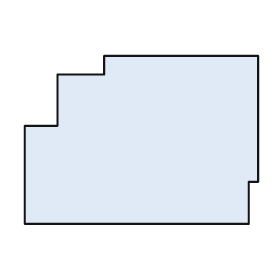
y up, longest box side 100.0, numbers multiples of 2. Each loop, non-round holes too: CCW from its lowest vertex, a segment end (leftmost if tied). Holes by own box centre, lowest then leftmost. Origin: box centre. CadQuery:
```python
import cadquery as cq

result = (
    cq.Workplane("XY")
    .moveTo(-50.0, -36.0)
    .lineTo(46.0, -36.0)
    .lineTo(46.0, -18.0)
    .lineTo(50.0, -18.0)
    .lineTo(50.0, 36.0)
    .lineTo(-16.0, 36.0)
    .lineTo(-16.0, 28.0)
    .lineTo(-36.0, 28.0)
    .lineTo(-36.0, 6.0)
    .lineTo(-50.0, 6.0)
    .close()
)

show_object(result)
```